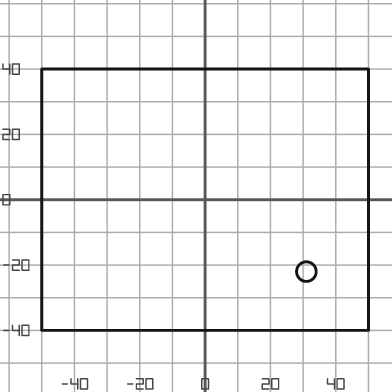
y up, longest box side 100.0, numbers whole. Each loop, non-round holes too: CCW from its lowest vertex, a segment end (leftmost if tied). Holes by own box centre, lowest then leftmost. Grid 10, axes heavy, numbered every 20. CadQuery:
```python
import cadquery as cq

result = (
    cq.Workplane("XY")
    .moveTo(-50.0, -40.0)
    .lineTo(50.0, -40.0)
    .lineTo(50.0, 40.0)
    .lineTo(-50.0, 40.0)
    .close()
    .moveTo(31.0, -22.0)
    .circle(3.0)
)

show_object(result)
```